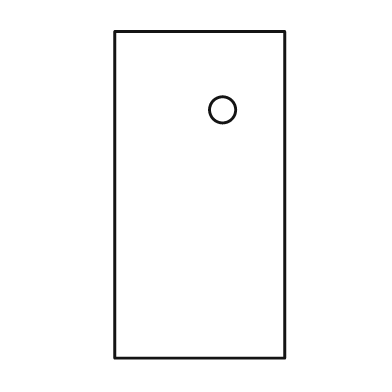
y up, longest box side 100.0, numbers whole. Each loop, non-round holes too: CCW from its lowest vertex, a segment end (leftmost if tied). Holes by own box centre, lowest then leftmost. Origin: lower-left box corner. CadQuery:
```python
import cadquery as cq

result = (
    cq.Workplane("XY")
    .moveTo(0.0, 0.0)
    .lineTo(52.0, 0.0)
    .lineTo(52.0, 100.0)
    .lineTo(0.0, 100.0)
    .close()
    .moveTo(33.0, 76.0)
    .circle(4.0)
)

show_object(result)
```